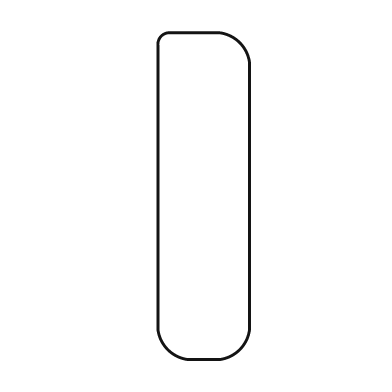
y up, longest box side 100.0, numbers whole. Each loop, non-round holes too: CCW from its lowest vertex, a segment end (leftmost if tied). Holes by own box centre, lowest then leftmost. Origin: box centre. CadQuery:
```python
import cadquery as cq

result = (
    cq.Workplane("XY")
    .moveTo(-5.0, -50.0)
    .lineTo(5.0, -50.0)
    .threePointArc((11.0, -47.0), (14.0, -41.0))
    .lineTo(14.0, 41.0)
    .threePointArc((11.0, 47.0), (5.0, 50.0))
    .lineTo(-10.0, 50.0)
    .threePointArc((-13.0, 49.0), (-14.0, 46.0))
    .lineTo(-14.0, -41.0)
    .threePointArc((-11.0, -47.0), (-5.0, -50.0))
    .close()
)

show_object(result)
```